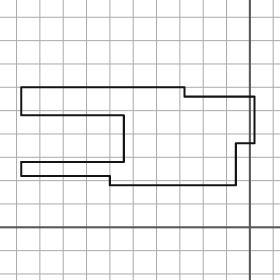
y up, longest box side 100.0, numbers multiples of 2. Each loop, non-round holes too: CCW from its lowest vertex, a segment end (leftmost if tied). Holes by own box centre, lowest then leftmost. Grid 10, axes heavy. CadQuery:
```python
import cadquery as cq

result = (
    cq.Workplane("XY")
    .moveTo(-60.0, 18.0)
    .lineTo(-6.0, 18.0)
    .lineTo(-6.0, 36.0)
    .lineTo(2.0, 36.0)
    .lineTo(2.0, 56.0)
    .lineTo(-28.0, 56.0)
    .lineTo(-28.0, 60.0)
    .lineTo(-98.0, 60.0)
    .lineTo(-98.0, 48.0)
    .lineTo(-54.0, 48.0)
    .lineTo(-54.0, 28.0)
    .lineTo(-98.0, 28.0)
    .lineTo(-98.0, 22.0)
    .lineTo(-60.0, 22.0)
    .close()
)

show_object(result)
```